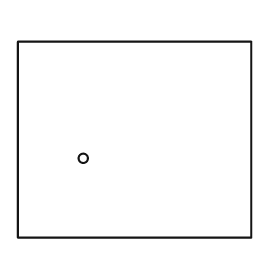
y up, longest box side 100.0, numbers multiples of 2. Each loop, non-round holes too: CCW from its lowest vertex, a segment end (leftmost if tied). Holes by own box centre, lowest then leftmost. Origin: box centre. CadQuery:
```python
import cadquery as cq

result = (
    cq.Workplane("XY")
    .moveTo(-50.0, -42.0)
    .lineTo(50.0, -42.0)
    .lineTo(50.0, 42.0)
    .lineTo(-50.0, 42.0)
    .close()
    .moveTo(-22.0, -8.0)
    .circle(2.0)
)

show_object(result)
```